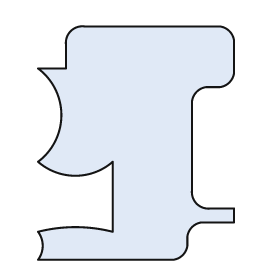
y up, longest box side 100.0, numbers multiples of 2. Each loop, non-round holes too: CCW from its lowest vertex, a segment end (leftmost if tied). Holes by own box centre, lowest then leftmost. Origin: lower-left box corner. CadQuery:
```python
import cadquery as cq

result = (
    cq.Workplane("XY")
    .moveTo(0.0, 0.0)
    .lineTo(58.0, 0.0)
    .threePointArc((62.0, 2.0), (64.0, 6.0))
    .lineTo(64.0, 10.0)
    .threePointArc((66.0, 14.0), (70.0, 16.0))
    .lineTo(84.0, 16.0)
    .lineTo(84.0, 22.0)
    .lineTo(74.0, 22.0)
    .threePointArc((68.0, 24.0), (66.0, 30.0))
    .lineTo(66.0, 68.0)
    .threePointArc((68.0, 72.0), (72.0, 74.0))
    .lineTo(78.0, 74.0)
    .threePointArc((82.0, 76.0), (84.0, 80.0))
    .lineTo(84.0, 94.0)
    .threePointArc((82.0, 98.0), (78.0, 100.0))
    .lineTo(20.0, 100.0)
    .threePointArc((14.0, 98.0), (12.0, 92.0))
    .lineTo(12.0, 82.0)
    .lineTo(0.0, 82.0)
    .threePointArc((10.0, 62.0), (0.0, 42.0))
    .threePointArc((16.0, 36.0), (32.0, 42.0))
    .lineTo(32.0, 12.0)
    .threePointArc((16.0, 14.0), (0.0, 12.0))
    .threePointArc((2.0, 6.0), (0.0, 0.0))
    .close()
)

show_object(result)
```